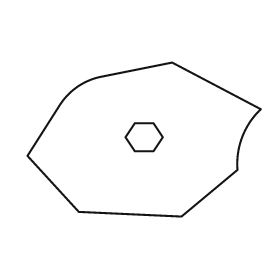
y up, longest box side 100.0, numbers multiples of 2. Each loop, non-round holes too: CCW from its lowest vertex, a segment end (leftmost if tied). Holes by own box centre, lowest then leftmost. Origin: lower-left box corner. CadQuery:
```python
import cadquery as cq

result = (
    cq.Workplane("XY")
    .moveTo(66.0, 0.0)
    .lineTo(90.0, 20.0)
    .threePointArc((92.0, 34.0), (100.0, 46.0))
    .lineTo(62.0, 66.0)
    .lineTo(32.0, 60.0)
    .threePointArc((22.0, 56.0), (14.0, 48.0))
    .lineTo(0.0, 26.0)
    .lineTo(22.0, 2.0)
    .close()
    .moveTo(46.0, 28.0)
    .lineTo(54.0, 28.0)
    .lineTo(58.0, 34.0)
    .lineTo(54.0, 40.0)
    .lineTo(46.0, 40.0)
    .lineTo(42.0, 34.0)
    .close()
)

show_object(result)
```